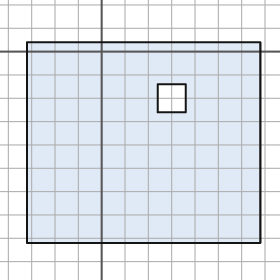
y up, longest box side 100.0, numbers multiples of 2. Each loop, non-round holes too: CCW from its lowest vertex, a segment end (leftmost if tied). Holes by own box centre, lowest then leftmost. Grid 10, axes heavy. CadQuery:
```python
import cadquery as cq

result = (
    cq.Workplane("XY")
    .moveTo(-32.0, -82.0)
    .lineTo(68.0, -82.0)
    .lineTo(68.0, 4.0)
    .lineTo(-32.0, 4.0)
    .close()
    .moveTo(24.0, -26.0)
    .lineTo(36.0, -26.0)
    .lineTo(36.0, -14.0)
    .lineTo(24.0, -14.0)
    .close()
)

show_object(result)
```